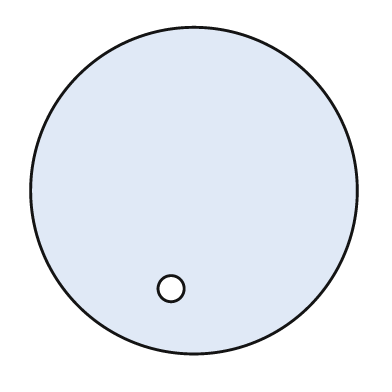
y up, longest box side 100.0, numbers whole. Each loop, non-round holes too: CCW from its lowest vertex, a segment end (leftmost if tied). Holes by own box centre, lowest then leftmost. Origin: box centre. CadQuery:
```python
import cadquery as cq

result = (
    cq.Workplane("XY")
    .moveTo(0.0, 0.0)
    .circle(50.0)
    .moveTo(-7.0, -30.0)
    .circle(4.0)
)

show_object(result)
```